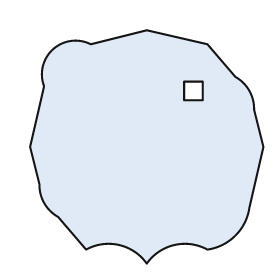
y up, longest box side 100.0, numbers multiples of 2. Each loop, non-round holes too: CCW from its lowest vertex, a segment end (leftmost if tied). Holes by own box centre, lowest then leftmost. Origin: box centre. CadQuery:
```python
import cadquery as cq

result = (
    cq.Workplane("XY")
    .moveTo(0.0, -50.0)
    .threePointArc((12.0, -42.0), (26.0, -44.0))
    .threePointArc((38.0, -38.0), (44.0, -26.0))
    .lineTo(50.0, 0.0)
    .lineTo(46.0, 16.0)
    .threePointArc((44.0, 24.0), (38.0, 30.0))
    .lineTo(26.0, 44.0)
    .lineTo(0.0, 50.0)
    .lineTo(-24.0, 44.0)
    .threePointArc((-40.0, 42.0), (-44.0, 26.0))
    .lineTo(-50.0, 0.0)
    .lineTo(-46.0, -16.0)
    .threePointArc((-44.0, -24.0), (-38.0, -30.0))
    .lineTo(-26.0, -44.0)
    .threePointArc((-12.0, -42.0), (0.0, -50.0))
    .close()
    .moveTo(16.0, 20.0)
    .lineTo(24.0, 20.0)
    .lineTo(24.0, 28.0)
    .lineTo(16.0, 28.0)
    .close()
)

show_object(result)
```